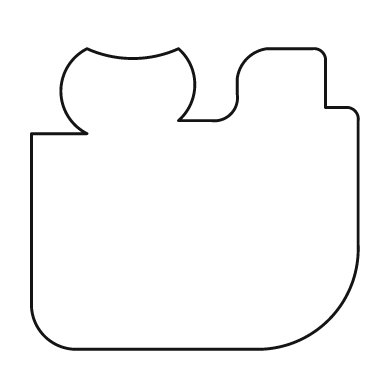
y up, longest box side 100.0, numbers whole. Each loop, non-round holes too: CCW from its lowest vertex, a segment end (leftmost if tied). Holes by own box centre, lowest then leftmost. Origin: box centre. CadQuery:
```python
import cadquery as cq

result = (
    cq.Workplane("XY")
    .moveTo(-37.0, -46.0)
    .lineTo(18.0, -46.0)
    .threePointArc((41.0, -37.0), (50.0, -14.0))
    .lineTo(50.0, 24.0)
    .threePointArc((49.0, 27.0), (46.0, 28.0))
    .lineTo(40.0, 28.0)
    .lineTo(40.0, 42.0)
    .threePointArc((39.0, 45.0), (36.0, 46.0))
    .lineTo(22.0, 46.0)
    .threePointArc((16.0, 43.0), (13.0, 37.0))
    .lineTo(13.0, 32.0)
    .threePointArc((11.0, 26.0), (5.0, 24.0))
    .lineTo(-5.0, 24.0)
    .threePointArc((0.0, 35.0), (-5.0, 46.0))
    .threePointArc((-19.0, 43.0), (-33.0, 46.0))
    .threePointArc((-41.0, 33.0), (-33.0, 20.0))
    .lineTo(-50.0, 20.0)
    .lineTo(-50.0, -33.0)
    .threePointArc((-46.0, -42.0), (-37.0, -46.0))
    .close()
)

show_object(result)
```